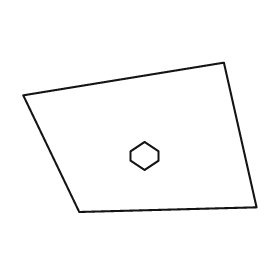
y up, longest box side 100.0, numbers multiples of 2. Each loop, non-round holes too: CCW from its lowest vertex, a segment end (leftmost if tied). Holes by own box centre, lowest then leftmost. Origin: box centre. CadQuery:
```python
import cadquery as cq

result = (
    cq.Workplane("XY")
    .moveTo(-26.0, -32.0)
    .lineTo(50.0, -30.0)
    .lineTo(36.0, 32.0)
    .lineTo(-50.0, 18.0)
    .close()
    .moveTo(2.0, -14.0)
    .lineTo(8.0, -10.0)
    .lineTo(8.0, -6.0)
    .lineTo(2.0, -2.0)
    .lineTo(-4.0, -6.0)
    .lineTo(-4.0, -10.0)
    .close()
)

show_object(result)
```